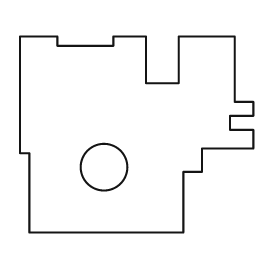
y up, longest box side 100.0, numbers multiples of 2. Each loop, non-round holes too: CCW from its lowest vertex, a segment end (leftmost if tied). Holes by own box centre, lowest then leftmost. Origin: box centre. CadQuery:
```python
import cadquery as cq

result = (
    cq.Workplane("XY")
    .moveTo(-46.0, -42.0)
    .lineTo(20.0, -42.0)
    .lineTo(20.0, -16.0)
    .lineTo(28.0, -16.0)
    .lineTo(28.0, -6.0)
    .lineTo(50.0, -6.0)
    .lineTo(50.0, 2.0)
    .lineTo(40.0, 2.0)
    .lineTo(40.0, 8.0)
    .lineTo(50.0, 8.0)
    .lineTo(50.0, 14.0)
    .lineTo(42.0, 14.0)
    .lineTo(42.0, 42.0)
    .lineTo(18.0, 42.0)
    .lineTo(18.0, 22.0)
    .lineTo(4.0, 22.0)
    .lineTo(4.0, 42.0)
    .lineTo(-10.0, 42.0)
    .lineTo(-10.0, 38.0)
    .lineTo(-34.0, 38.0)
    .lineTo(-34.0, 42.0)
    .lineTo(-50.0, 42.0)
    .lineTo(-50.0, -8.0)
    .lineTo(-46.0, -8.0)
    .close()
    .moveTo(-14.0, -14.0)
    .circle(10.0)
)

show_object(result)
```